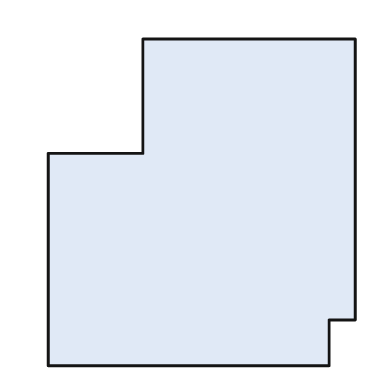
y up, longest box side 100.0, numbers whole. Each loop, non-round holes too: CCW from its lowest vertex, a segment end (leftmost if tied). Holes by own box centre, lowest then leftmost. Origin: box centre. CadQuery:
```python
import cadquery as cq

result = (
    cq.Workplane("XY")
    .moveTo(-47.0, -50.0)
    .lineTo(39.0, -50.0)
    .lineTo(39.0, -36.0)
    .lineTo(47.0, -36.0)
    .lineTo(47.0, 50.0)
    .lineTo(-18.0, 50.0)
    .lineTo(-18.0, 15.0)
    .lineTo(-47.0, 15.0)
    .close()
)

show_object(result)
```